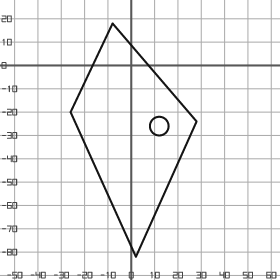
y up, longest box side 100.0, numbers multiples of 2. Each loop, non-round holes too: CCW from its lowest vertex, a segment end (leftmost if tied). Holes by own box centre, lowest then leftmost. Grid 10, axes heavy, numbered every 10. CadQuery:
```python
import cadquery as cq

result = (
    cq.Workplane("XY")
    .moveTo(2.0, -82.0)
    .lineTo(28.0, -24.0)
    .lineTo(-8.0, 18.0)
    .lineTo(-26.0, -20.0)
    .close()
    .moveTo(12.0, -26.0)
    .circle(4.0)
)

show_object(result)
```